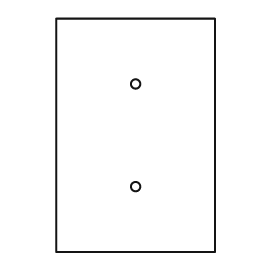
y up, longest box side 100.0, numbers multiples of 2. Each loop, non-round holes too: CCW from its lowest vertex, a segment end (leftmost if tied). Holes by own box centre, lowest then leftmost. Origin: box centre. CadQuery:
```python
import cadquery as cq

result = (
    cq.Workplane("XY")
    .moveTo(-34.0, -50.0)
    .lineTo(34.0, -50.0)
    .lineTo(34.0, 50.0)
    .lineTo(-34.0, 50.0)
    .close()
    .moveTo(0.0, -22.0)
    .circle(2.0)
    .moveTo(0.0, 22.0)
    .circle(2.0)
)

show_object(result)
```